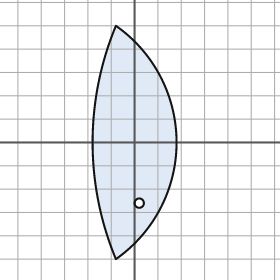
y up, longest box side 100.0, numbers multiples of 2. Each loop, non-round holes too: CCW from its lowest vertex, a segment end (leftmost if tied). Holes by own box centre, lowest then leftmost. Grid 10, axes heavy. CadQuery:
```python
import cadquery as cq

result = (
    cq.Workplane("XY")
    .moveTo(-8.0, -50.0)
    .threePointArc((18.0, 0.0), (-8.0, 50.0))
    .threePointArc((-18.0, 0.0), (-8.0, -50.0))
    .close()
    .moveTo(2.0, -26.0)
    .circle(2.0)
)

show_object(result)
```